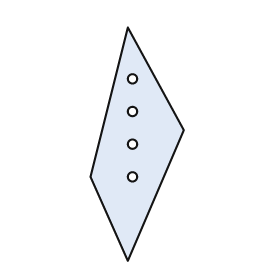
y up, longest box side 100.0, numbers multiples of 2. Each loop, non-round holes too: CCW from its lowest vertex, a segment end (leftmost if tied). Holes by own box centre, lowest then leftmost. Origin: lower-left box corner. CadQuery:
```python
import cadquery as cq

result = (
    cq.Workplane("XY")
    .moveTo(16.0, 0.0)
    .lineTo(40.0, 56.0)
    .lineTo(16.0, 100.0)
    .lineTo(0.0, 36.0)
    .close()
    .moveTo(18.0, 36.0)
    .circle(2.0)
    .moveTo(18.0, 50.0)
    .circle(2.0)
    .moveTo(18.0, 64.0)
    .circle(2.0)
    .moveTo(18.0, 78.0)
    .circle(2.0)
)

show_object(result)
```